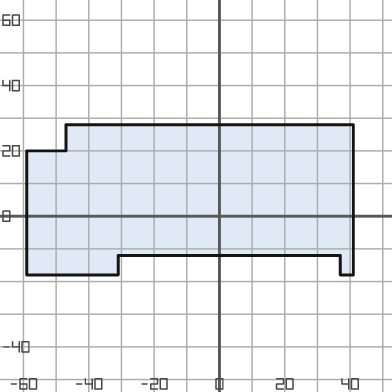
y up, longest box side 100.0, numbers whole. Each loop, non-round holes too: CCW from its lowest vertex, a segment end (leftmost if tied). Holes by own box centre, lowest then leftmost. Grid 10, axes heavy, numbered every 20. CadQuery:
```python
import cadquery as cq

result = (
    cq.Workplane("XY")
    .moveTo(-59.0, -18.0)
    .lineTo(-31.0, -18.0)
    .lineTo(-31.0, -12.0)
    .lineTo(37.0, -12.0)
    .lineTo(37.0, -18.0)
    .lineTo(41.0, -18.0)
    .lineTo(41.0, 28.0)
    .lineTo(-47.0, 28.0)
    .lineTo(-47.0, 20.0)
    .lineTo(-59.0, 20.0)
    .close()
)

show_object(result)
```